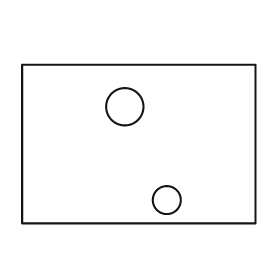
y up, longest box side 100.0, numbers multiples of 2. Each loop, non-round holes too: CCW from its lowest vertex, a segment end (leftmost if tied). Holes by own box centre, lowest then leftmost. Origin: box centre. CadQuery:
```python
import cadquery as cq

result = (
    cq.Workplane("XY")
    .moveTo(-50.0, -34.0)
    .lineTo(50.0, -34.0)
    .lineTo(50.0, 34.0)
    .lineTo(-50.0, 34.0)
    .close()
    .moveTo(12.0, -24.0)
    .circle(6.0)
    .moveTo(-6.0, 16.0)
    .circle(8.0)
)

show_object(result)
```